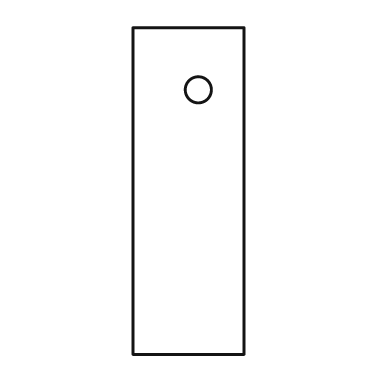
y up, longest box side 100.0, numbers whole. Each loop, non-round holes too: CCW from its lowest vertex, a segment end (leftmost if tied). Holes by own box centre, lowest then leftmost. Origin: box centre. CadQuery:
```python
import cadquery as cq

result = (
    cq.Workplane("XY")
    .moveTo(-17.0, -50.0)
    .lineTo(17.0, -50.0)
    .lineTo(17.0, 50.0)
    .lineTo(-17.0, 50.0)
    .close()
    .moveTo(3.0, 31.0)
    .circle(4.0)
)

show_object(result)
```